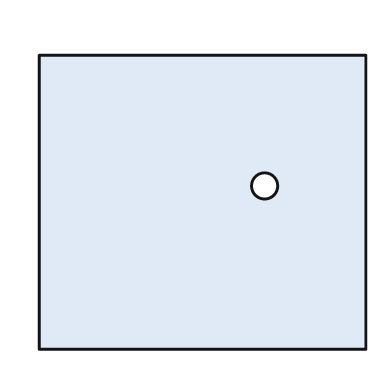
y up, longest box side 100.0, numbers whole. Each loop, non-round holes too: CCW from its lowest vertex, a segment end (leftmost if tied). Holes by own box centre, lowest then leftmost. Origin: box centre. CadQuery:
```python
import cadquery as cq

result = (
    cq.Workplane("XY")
    .moveTo(-50.0, -45.0)
    .lineTo(50.0, -45.0)
    .lineTo(50.0, 45.0)
    .lineTo(-50.0, 45.0)
    .close()
    .moveTo(19.0, 5.0)
    .circle(4.0)
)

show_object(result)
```